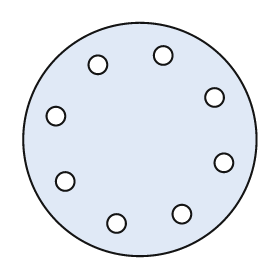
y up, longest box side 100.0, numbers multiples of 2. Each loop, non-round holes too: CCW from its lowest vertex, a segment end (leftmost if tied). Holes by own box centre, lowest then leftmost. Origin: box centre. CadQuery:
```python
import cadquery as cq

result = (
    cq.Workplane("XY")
    .moveTo(0.0, 0.0)
    .circle(50.0)
    .moveTo(-10.0, -36.0)
    .circle(4.0)
    .moveTo(18.0, -32.0)
    .circle(4.0)
    .moveTo(-32.0, -18.0)
    .circle(4.0)
    .moveTo(36.0, -10.0)
    .circle(4.0)
    .moveTo(-36.0, 10.0)
    .circle(4.0)
    .moveTo(32.0, 18.0)
    .circle(4.0)
    .moveTo(-18.0, 32.0)
    .circle(4.0)
    .moveTo(10.0, 36.0)
    .circle(4.0)
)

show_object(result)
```